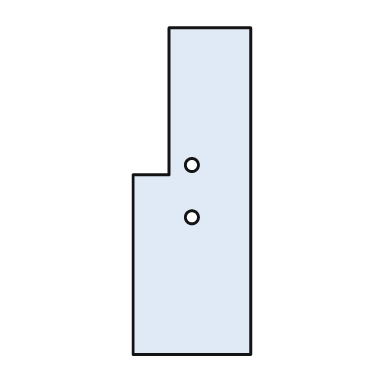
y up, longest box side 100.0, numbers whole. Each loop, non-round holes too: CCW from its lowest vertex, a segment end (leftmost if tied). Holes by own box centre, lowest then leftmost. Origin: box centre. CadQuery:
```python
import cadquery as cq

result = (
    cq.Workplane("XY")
    .moveTo(-18.0, -50.0)
    .lineTo(18.0, -50.0)
    .lineTo(18.0, 50.0)
    .lineTo(-7.0, 50.0)
    .lineTo(-7.0, 5.0)
    .lineTo(-18.0, 5.0)
    .close()
    .moveTo(0.0, -8.0)
    .circle(2.0)
    .moveTo(0.0, 8.0)
    .circle(2.0)
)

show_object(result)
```